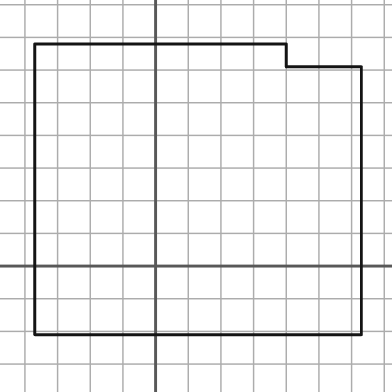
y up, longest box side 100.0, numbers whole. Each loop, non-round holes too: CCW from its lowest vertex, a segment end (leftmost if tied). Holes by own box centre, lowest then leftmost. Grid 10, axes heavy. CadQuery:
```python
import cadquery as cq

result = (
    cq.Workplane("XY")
    .moveTo(-37.0, -21.0)
    .lineTo(63.0, -21.0)
    .lineTo(63.0, 61.0)
    .lineTo(40.0, 61.0)
    .lineTo(40.0, 68.0)
    .lineTo(-37.0, 68.0)
    .close()
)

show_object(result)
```